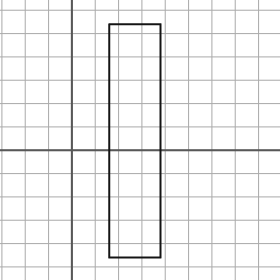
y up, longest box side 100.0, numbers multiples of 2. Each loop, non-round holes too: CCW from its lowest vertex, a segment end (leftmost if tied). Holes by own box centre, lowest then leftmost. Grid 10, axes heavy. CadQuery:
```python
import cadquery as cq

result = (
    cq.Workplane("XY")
    .moveTo(16.0, -46.0)
    .lineTo(38.0, -46.0)
    .lineTo(38.0, 54.0)
    .lineTo(16.0, 54.0)
    .close()
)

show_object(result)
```